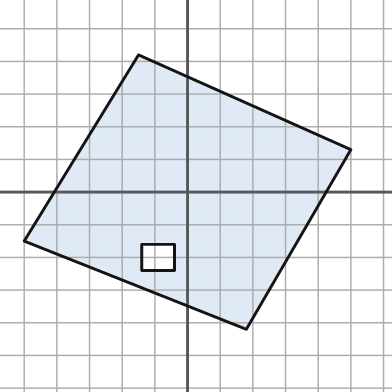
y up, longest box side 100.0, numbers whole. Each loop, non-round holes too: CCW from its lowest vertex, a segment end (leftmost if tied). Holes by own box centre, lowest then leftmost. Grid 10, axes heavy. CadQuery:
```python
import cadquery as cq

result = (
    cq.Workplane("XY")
    .moveTo(18.0, -42.0)
    .lineTo(50.0, 13.0)
    .lineTo(-15.0, 42.0)
    .lineTo(-50.0, -15.0)
    .close()
    .moveTo(-14.0, -24.0)
    .lineTo(-4.0, -24.0)
    .lineTo(-4.0, -16.0)
    .lineTo(-14.0, -16.0)
    .close()
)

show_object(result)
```